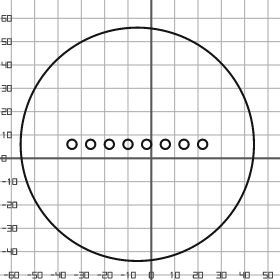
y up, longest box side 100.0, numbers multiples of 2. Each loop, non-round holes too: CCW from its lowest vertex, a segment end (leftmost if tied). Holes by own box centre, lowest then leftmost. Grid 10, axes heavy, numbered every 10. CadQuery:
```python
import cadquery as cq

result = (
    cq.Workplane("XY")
    .moveTo(-6.0, 6.0)
    .circle(50.0)
    .moveTo(-34.0, 6.0)
    .circle(2.0)
    .moveTo(-26.0, 6.0)
    .circle(2.0)
    .moveTo(-18.0, 6.0)
    .circle(2.0)
    .moveTo(-10.0, 6.0)
    .circle(2.0)
    .moveTo(-2.0, 6.0)
    .circle(2.0)
    .moveTo(6.0, 6.0)
    .circle(2.0)
    .moveTo(14.0, 6.0)
    .circle(2.0)
    .moveTo(22.0, 6.0)
    .circle(2.0)
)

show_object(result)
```